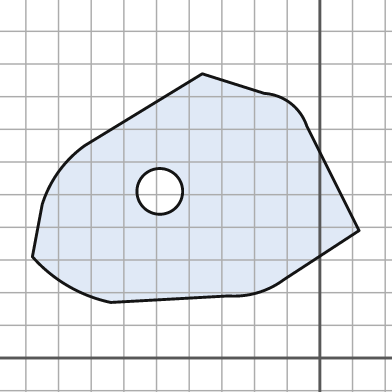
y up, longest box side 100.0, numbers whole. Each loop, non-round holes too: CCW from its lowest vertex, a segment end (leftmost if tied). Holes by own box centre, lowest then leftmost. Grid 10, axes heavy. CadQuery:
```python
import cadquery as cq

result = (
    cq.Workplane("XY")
    .moveTo(-64.0, 17.0)
    .lineTo(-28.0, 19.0)
    .threePointArc((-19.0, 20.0), (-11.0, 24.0))
    .lineTo(12.0, 39.0)
    .lineTo(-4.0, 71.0)
    .threePointArc((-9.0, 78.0), (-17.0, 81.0))
    .lineTo(-36.0, 87.0)
    .lineTo(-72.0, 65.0)
    .threePointArc((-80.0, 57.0), (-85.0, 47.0))
    .lineTo(-88.0, 31.0)
    .threePointArc((-77.0, 22.0), (-64.0, 17.0))
    .close()
    .moveTo(-49.0, 51.0)
    .circle(7.0)
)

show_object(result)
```